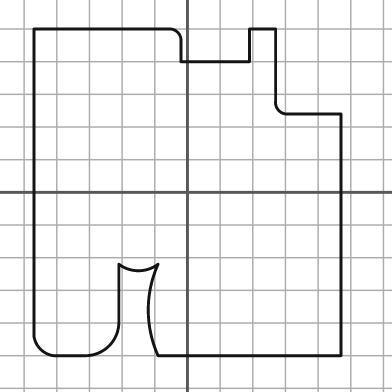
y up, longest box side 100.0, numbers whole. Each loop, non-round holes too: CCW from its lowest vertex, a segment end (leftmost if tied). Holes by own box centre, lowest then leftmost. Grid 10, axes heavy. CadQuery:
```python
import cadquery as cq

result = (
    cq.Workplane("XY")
    .moveTo(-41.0, -50.0)
    .lineTo(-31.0, -50.0)
    .threePointArc((-24.0, -47.0), (-21.0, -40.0))
    .lineTo(-21.0, -22.0)
    .threePointArc((-15.0, -24.0), (-9.0, -22.0))
    .threePointArc((-12.0, -36.0), (-9.0, -50.0))
    .lineTo(47.0, -50.0)
    .lineTo(47.0, 24.0)
    .lineTo(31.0, 24.0)
    .threePointArc((28.0, 25.0), (27.0, 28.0))
    .lineTo(27.0, 50.0)
    .lineTo(19.0, 50.0)
    .lineTo(19.0, 40.0)
    .lineTo(-2.0, 40.0)
    .lineTo(-2.0, 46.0)
    .threePointArc((-3.0, 49.0), (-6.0, 50.0))
    .lineTo(-47.0, 50.0)
    .lineTo(-47.0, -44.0)
    .threePointArc((-45.0, -48.0), (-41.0, -50.0))
    .close()
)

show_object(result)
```